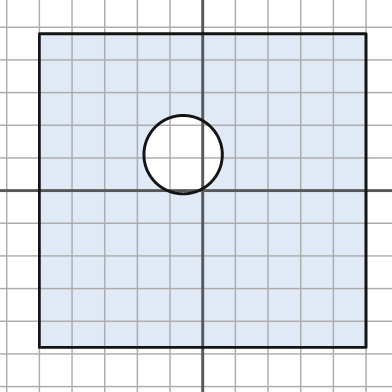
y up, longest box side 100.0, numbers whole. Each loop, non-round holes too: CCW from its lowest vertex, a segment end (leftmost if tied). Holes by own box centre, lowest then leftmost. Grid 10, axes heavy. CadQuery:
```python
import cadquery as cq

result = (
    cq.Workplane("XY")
    .moveTo(-50.0, -48.0)
    .lineTo(50.0, -48.0)
    .lineTo(50.0, 48.0)
    .lineTo(-50.0, 48.0)
    .close()
    .moveTo(-6.0, 11.0)
    .circle(12.0)
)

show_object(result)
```